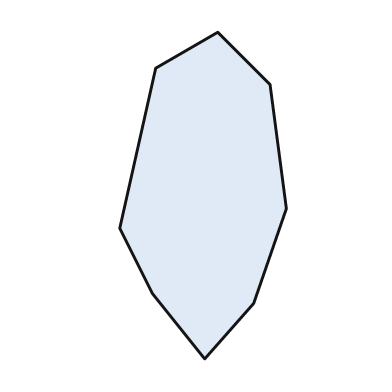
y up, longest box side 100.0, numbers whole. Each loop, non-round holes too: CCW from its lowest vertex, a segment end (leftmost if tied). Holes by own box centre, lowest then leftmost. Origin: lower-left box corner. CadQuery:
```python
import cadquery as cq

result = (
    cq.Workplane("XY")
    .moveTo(26.0, 0.0)
    .lineTo(41.0, 17.0)
    .lineTo(51.0, 46.0)
    .lineTo(46.0, 84.0)
    .lineTo(30.0, 100.0)
    .lineTo(11.0, 89.0)
    .lineTo(0.0, 40.0)
    .lineTo(10.0, 20.0)
    .close()
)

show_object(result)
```